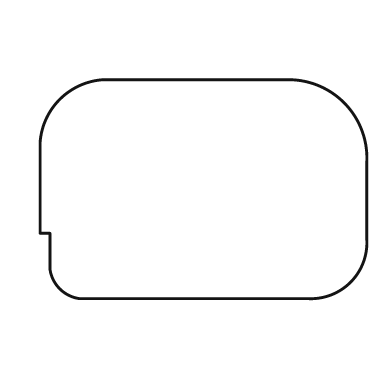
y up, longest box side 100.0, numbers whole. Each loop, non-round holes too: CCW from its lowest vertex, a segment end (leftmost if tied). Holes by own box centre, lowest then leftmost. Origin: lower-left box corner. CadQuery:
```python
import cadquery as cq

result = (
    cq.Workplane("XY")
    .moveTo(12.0, 0.0)
    .lineTo(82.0, 0.0)
    .threePointArc((95.0, 5.0), (100.0, 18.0))
    .lineTo(100.0, 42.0)
    .threePointArc((93.0, 60.0), (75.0, 67.0))
    .lineTo(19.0, 67.0)
    .threePointArc((6.0, 61.0), (0.0, 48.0))
    .lineTo(0.0, 20.0)
    .lineTo(3.0, 20.0)
    .lineTo(3.0, 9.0)
    .threePointArc((6.0, 3.0), (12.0, 0.0))
    .close()
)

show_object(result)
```